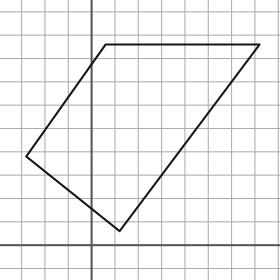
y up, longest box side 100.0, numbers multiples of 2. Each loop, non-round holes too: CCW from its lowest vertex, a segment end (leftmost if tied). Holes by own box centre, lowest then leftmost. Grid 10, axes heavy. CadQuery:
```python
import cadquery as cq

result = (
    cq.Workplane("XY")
    .moveTo(12.0, 6.0)
    .lineTo(72.0, 86.0)
    .lineTo(6.0, 86.0)
    .lineTo(-28.0, 38.0)
    .close()
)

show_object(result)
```